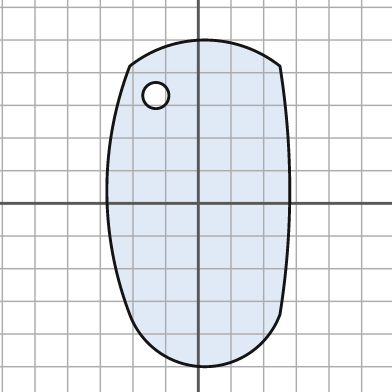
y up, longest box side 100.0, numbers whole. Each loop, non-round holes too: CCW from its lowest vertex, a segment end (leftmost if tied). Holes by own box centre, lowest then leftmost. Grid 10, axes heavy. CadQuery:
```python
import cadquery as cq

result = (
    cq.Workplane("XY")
    .moveTo(-21.0, -34.0)
    .threePointArc((2.0, -50.0), (25.0, -34.0))
    .threePointArc((28.0, 4.0), (25.0, 42.0))
    .threePointArc((2.0, 50.0), (-21.0, 42.0))
    .threePointArc((-28.0, 4.0), (-21.0, -34.0))
    .close()
    .moveTo(-13.0, 33.0)
    .circle(4.0)
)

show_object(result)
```